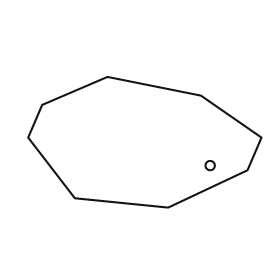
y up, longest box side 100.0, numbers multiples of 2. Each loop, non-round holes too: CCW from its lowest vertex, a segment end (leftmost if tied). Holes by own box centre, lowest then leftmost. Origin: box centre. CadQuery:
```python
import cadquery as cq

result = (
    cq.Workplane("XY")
    .moveTo(10.0, -28.0)
    .lineTo(44.0, -12.0)
    .lineTo(50.0, 2.0)
    .lineTo(24.0, 20.0)
    .lineTo(-16.0, 28.0)
    .lineTo(-44.0, 16.0)
    .lineTo(-50.0, 2.0)
    .lineTo(-30.0, -24.0)
    .close()
    .moveTo(28.0, -10.0)
    .circle(2.0)
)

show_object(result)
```